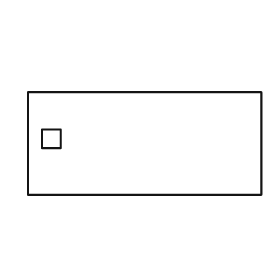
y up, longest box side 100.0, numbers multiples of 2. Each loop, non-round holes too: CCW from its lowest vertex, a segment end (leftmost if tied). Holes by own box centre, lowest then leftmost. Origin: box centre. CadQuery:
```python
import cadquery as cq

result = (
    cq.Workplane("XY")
    .moveTo(-50.0, -22.0)
    .lineTo(50.0, -22.0)
    .lineTo(50.0, 22.0)
    .lineTo(-50.0, 22.0)
    .close()
    .moveTo(-44.0, -2.0)
    .lineTo(-36.0, -2.0)
    .lineTo(-36.0, 6.0)
    .lineTo(-44.0, 6.0)
    .close()
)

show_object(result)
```